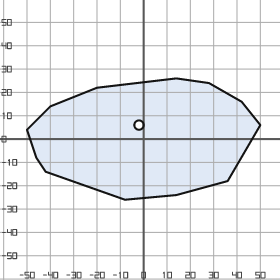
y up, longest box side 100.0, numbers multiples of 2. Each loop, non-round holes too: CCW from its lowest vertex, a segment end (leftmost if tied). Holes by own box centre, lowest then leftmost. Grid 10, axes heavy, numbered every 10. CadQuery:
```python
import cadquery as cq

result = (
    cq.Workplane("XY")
    .moveTo(-8.0, -26.0)
    .lineTo(14.0, -24.0)
    .lineTo(36.0, -18.0)
    .lineTo(50.0, 6.0)
    .lineTo(42.0, 16.0)
    .lineTo(28.0, 24.0)
    .lineTo(14.0, 26.0)
    .lineTo(-20.0, 22.0)
    .lineTo(-40.0, 14.0)
    .lineTo(-50.0, 4.0)
    .lineTo(-46.0, -8.0)
    .lineTo(-42.0, -14.0)
    .close()
    .moveTo(-2.0, 6.0)
    .circle(2.0)
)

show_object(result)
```